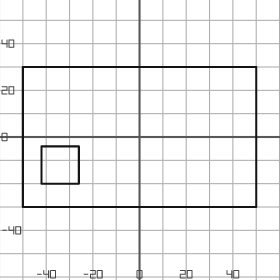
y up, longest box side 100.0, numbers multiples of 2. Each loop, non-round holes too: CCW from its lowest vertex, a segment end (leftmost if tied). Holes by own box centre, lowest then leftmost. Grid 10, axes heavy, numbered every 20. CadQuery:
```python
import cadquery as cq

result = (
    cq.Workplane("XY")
    .moveTo(-50.0, -30.0)
    .lineTo(50.0, -30.0)
    .lineTo(50.0, 30.0)
    .lineTo(-50.0, 30.0)
    .close()
    .moveTo(-42.0, -20.0)
    .lineTo(-26.0, -20.0)
    .lineTo(-26.0, -4.0)
    .lineTo(-42.0, -4.0)
    .close()
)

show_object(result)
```